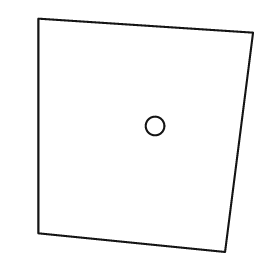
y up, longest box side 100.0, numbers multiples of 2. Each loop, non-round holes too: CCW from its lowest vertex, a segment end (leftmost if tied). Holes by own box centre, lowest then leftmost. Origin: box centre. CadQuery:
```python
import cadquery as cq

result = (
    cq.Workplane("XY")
    .moveTo(34.0, -50.0)
    .lineTo(46.0, 44.0)
    .lineTo(-46.0, 50.0)
    .lineTo(-46.0, -42.0)
    .close()
    .moveTo(4.0, 4.0)
    .circle(4.0)
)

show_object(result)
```